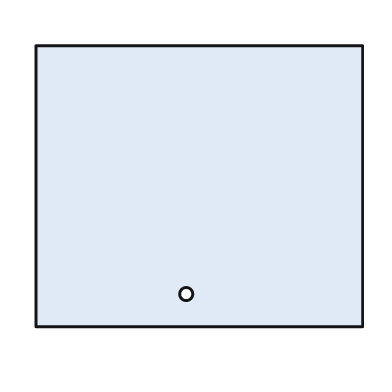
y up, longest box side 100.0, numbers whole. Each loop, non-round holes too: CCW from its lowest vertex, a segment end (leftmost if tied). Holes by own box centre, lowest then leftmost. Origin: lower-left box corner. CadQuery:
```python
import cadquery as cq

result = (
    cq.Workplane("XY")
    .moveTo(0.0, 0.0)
    .lineTo(100.0, 0.0)
    .lineTo(100.0, 86.0)
    .lineTo(0.0, 86.0)
    .close()
    .moveTo(46.0, 10.0)
    .circle(2.0)
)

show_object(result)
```